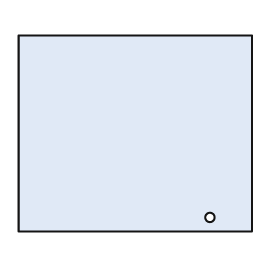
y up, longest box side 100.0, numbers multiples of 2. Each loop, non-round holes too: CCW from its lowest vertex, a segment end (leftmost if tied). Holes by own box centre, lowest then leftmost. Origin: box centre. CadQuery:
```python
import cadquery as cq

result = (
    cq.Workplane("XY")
    .moveTo(-50.0, -42.0)
    .lineTo(50.0, -42.0)
    .lineTo(50.0, 42.0)
    .lineTo(-50.0, 42.0)
    .close()
    .moveTo(32.0, -36.0)
    .circle(2.0)
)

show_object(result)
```